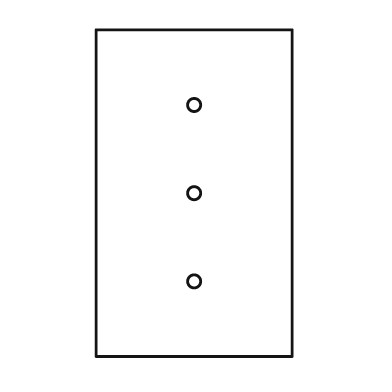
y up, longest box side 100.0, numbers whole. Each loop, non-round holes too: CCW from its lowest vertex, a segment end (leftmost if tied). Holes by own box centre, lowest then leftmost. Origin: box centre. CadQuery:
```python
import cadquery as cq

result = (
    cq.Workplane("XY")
    .moveTo(-30.0, -50.0)
    .lineTo(30.0, -50.0)
    .lineTo(30.0, 50.0)
    .lineTo(-30.0, 50.0)
    .close()
    .moveTo(0.0, -27.0)
    .circle(2.0)
    .moveTo(0.0, 0.0)
    .circle(2.0)
    .moveTo(0.0, 27.0)
    .circle(2.0)
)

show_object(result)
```